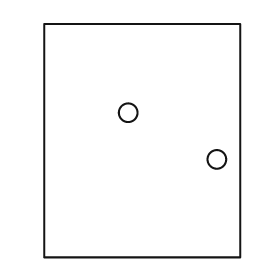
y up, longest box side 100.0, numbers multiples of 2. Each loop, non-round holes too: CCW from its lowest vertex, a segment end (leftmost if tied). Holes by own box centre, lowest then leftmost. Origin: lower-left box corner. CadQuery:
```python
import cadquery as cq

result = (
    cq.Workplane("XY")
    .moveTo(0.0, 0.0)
    .lineTo(84.0, 0.0)
    .lineTo(84.0, 100.0)
    .lineTo(0.0, 100.0)
    .close()
    .moveTo(74.0, 42.0)
    .circle(4.0)
    .moveTo(36.0, 62.0)
    .circle(4.0)
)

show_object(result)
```